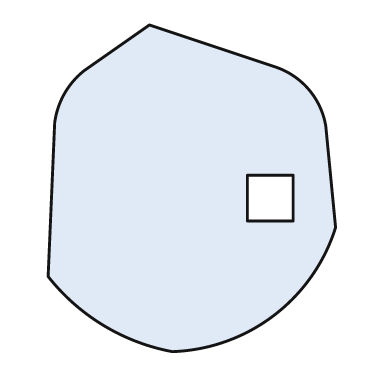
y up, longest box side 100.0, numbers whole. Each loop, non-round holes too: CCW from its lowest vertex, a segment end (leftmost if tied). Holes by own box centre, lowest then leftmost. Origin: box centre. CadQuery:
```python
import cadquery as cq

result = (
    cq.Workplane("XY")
    .moveTo(-6.0, -50.0)
    .threePointArc((25.0, -39.0), (44.0, -12.0))
    .lineTo(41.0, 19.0)
    .threePointArc((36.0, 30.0), (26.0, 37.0))
    .lineTo(-13.0, 50.0)
    .lineTo(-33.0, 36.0)
    .threePointArc((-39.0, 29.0), (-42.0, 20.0))
    .lineTo(-44.0, -27.0)
    .threePointArc((-27.0, -42.0), (-6.0, -50.0))
    .close()
    .moveTo(17.0, -10.0)
    .lineTo(31.0, -10.0)
    .lineTo(31.0, 4.0)
    .lineTo(17.0, 4.0)
    .close()
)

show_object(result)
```